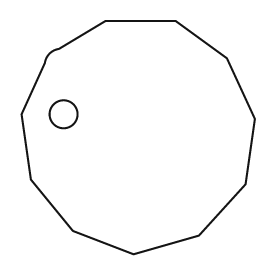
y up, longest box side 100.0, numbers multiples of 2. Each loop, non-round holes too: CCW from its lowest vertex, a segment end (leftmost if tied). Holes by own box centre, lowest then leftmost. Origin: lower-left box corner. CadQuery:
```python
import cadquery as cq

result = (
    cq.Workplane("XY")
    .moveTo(48.0, 0.0)
    .lineTo(76.0, 8.0)
    .lineTo(96.0, 30.0)
    .lineTo(100.0, 58.0)
    .lineTo(88.0, 84.0)
    .lineTo(66.0, 100.0)
    .lineTo(36.0, 100.0)
    .lineTo(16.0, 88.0)
    .threePointArc((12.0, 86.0), (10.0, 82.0))
    .lineTo(0.0, 60.0)
    .lineTo(4.0, 32.0)
    .lineTo(22.0, 10.0)
    .close()
    .moveTo(18.0, 60.0)
    .circle(6.0)
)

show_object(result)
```